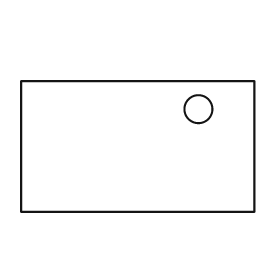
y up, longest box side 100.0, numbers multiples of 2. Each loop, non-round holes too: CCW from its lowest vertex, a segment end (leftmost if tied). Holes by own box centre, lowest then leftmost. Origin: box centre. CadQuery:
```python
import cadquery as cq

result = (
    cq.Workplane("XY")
    .moveTo(-50.0, -28.0)
    .lineTo(50.0, -28.0)
    .lineTo(50.0, 28.0)
    .lineTo(-50.0, 28.0)
    .close()
    .moveTo(26.0, 16.0)
    .circle(6.0)
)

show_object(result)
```